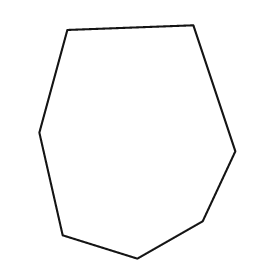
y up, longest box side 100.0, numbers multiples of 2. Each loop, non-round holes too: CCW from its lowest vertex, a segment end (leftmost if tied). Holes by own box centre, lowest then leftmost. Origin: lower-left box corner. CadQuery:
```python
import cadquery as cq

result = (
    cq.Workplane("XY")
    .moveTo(42.0, 0.0)
    .lineTo(70.0, 16.0)
    .lineTo(84.0, 46.0)
    .lineTo(66.0, 100.0)
    .lineTo(12.0, 98.0)
    .lineTo(0.0, 54.0)
    .lineTo(10.0, 10.0)
    .close()
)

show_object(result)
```